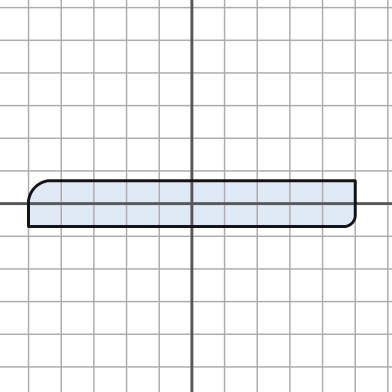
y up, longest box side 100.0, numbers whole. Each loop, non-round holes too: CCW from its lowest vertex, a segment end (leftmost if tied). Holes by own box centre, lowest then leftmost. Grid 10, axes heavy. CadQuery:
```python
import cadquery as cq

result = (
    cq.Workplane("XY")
    .moveTo(-50.0, -7.0)
    .lineTo(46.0, -7.0)
    .threePointArc((49.0, -6.0), (50.0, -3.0))
    .lineTo(50.0, 7.0)
    .lineTo(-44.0, 7.0)
    .threePointArc((-48.0, 5.0), (-50.0, 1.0))
    .close()
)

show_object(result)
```